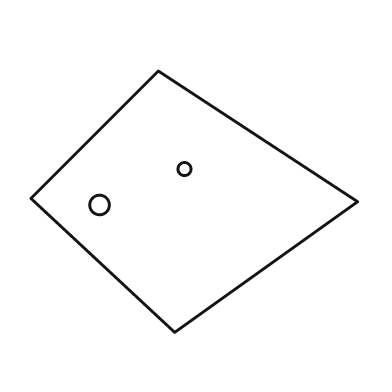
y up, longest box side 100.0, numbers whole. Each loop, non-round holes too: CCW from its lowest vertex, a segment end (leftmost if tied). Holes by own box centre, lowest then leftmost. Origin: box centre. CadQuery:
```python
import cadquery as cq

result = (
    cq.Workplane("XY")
    .moveTo(-6.0, -40.0)
    .lineTo(50.0, 0.0)
    .lineTo(-11.0, 40.0)
    .lineTo(-50.0, 1.0)
    .close()
    .moveTo(-29.0, -1.0)
    .circle(3.0)
    .moveTo(-3.0, 10.0)
    .circle(2.0)
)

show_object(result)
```